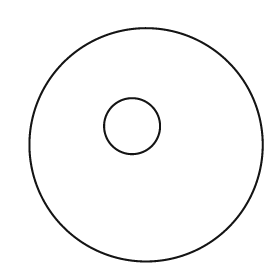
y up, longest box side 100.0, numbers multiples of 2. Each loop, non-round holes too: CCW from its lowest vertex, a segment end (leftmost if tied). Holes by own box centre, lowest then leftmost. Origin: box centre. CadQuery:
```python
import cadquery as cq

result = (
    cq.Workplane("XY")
    .moveTo(0.0, 0.0)
    .circle(50.0)
    .moveTo(-6.0, 8.0)
    .circle(12.0)
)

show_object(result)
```